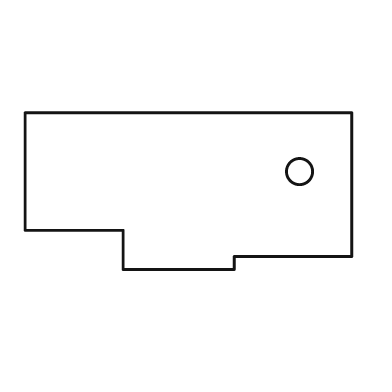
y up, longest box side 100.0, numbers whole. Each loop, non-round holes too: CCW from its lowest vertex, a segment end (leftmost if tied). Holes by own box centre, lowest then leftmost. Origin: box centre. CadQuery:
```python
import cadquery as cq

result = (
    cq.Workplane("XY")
    .moveTo(-20.0, -24.0)
    .lineTo(14.0, -24.0)
    .lineTo(14.0, -20.0)
    .lineTo(50.0, -20.0)
    .lineTo(50.0, 24.0)
    .lineTo(-50.0, 24.0)
    .lineTo(-50.0, -12.0)
    .lineTo(-20.0, -12.0)
    .close()
    .moveTo(34.0, 6.0)
    .circle(4.0)
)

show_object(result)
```